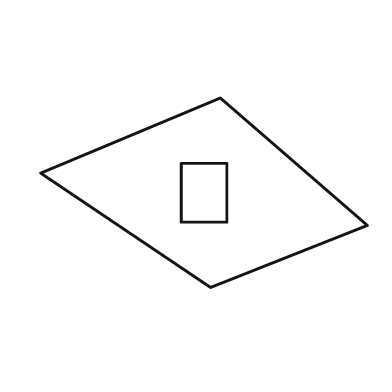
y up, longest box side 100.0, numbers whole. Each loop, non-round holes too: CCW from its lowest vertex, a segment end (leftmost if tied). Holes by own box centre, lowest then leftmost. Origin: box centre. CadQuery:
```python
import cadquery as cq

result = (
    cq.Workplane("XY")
    .moveTo(2.0, -29.0)
    .lineTo(50.0, -10.0)
    .lineTo(5.0, 29.0)
    .lineTo(-50.0, 6.0)
    .close()
    .moveTo(-7.0, -9.0)
    .lineTo(7.0, -9.0)
    .lineTo(7.0, 9.0)
    .lineTo(-7.0, 9.0)
    .close()
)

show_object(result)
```